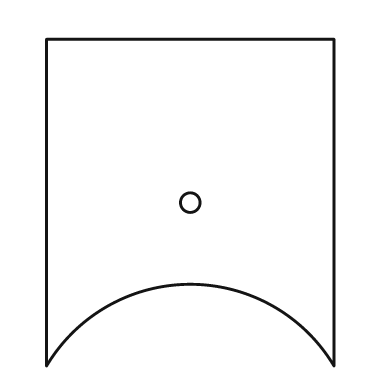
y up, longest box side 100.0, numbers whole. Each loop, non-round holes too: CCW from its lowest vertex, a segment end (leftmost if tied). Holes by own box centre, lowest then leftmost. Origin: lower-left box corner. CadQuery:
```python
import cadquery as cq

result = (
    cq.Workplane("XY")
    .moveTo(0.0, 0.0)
    .threePointArc((44.0, 25.0), (88.0, 0.0))
    .lineTo(88.0, 100.0)
    .lineTo(0.0, 100.0)
    .close()
    .moveTo(44.0, 50.0)
    .circle(3.0)
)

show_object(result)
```